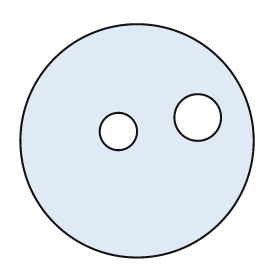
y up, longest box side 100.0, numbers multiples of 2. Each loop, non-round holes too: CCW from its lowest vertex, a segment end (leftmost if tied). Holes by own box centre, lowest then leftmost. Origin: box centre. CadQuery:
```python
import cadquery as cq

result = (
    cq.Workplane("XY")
    .moveTo(0.0, 0.0)
    .circle(50.0)
    .moveTo(-8.0, 4.0)
    .circle(8.0)
    .moveTo(26.0, 10.0)
    .circle(10.0)
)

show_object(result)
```